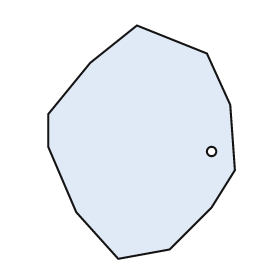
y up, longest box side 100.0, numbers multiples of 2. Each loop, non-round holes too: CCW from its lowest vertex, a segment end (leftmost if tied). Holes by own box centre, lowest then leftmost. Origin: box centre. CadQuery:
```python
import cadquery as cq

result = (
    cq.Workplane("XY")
    .moveTo(-10.0, -50.0)
    .lineTo(12.0, -46.0)
    .lineTo(30.0, -28.0)
    .lineTo(40.0, -12.0)
    .lineTo(38.0, 16.0)
    .lineTo(28.0, 38.0)
    .lineTo(-2.0, 50.0)
    .lineTo(-22.0, 34.0)
    .lineTo(-40.0, 12.0)
    .lineTo(-40.0, -2.0)
    .lineTo(-28.0, -30.0)
    .close()
    .moveTo(30.0, -4.0)
    .circle(2.0)
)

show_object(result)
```